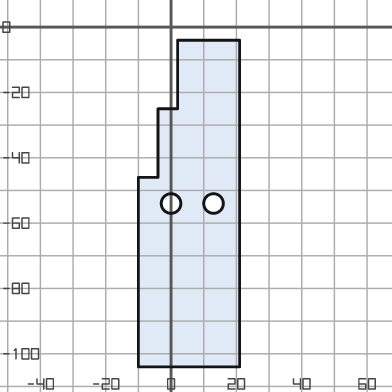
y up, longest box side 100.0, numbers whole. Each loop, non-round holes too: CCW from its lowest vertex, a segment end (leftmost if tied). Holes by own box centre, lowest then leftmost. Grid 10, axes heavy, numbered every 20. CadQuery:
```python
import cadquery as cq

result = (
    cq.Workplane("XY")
    .moveTo(-10.0, -104.0)
    .lineTo(21.0, -104.0)
    .lineTo(21.0, -4.0)
    .lineTo(2.0, -4.0)
    .lineTo(2.0, -25.0)
    .lineTo(-4.0, -25.0)
    .lineTo(-4.0, -46.0)
    .lineTo(-10.0, -46.0)
    .close()
    .moveTo(0.0, -54.0)
    .circle(3.0)
    .moveTo(13.0, -54.0)
    .circle(3.0)
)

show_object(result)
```